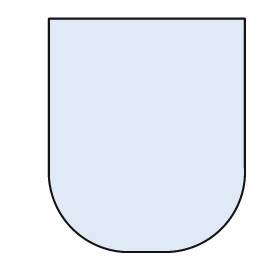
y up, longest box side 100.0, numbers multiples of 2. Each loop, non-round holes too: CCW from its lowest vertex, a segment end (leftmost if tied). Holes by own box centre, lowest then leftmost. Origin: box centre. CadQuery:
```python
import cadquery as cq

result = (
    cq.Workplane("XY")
    .moveTo(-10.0, -50.0)
    .lineTo(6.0, -50.0)
    .threePointArc((32.0, -40.0), (42.0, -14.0))
    .lineTo(42.0, 50.0)
    .lineTo(-42.0, 50.0)
    .lineTo(-42.0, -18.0)
    .threePointArc((-32.0, -40.0), (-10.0, -50.0))
    .close()
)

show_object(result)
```